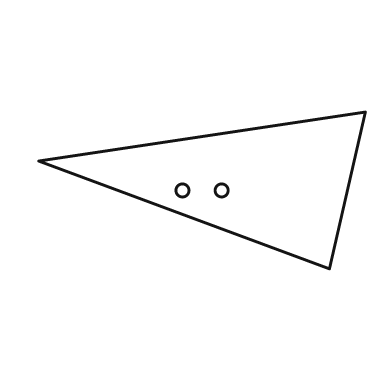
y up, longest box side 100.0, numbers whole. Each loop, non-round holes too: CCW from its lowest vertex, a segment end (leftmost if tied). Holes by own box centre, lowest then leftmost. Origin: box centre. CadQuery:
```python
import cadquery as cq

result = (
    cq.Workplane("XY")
    .moveTo(39.0, -24.0)
    .lineTo(50.0, 24.0)
    .lineTo(-50.0, 9.0)
    .close()
    .moveTo(-6.0, 0.0)
    .circle(2.0)
    .moveTo(6.0, 0.0)
    .circle(2.0)
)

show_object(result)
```